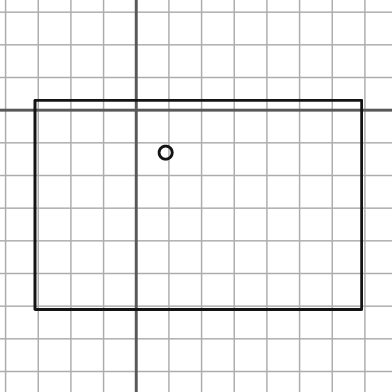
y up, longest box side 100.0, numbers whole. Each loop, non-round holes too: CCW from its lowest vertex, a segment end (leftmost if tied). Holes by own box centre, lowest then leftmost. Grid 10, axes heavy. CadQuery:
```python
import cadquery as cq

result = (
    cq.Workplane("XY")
    .moveTo(-31.0, -61.0)
    .lineTo(69.0, -61.0)
    .lineTo(69.0, 3.0)
    .lineTo(-31.0, 3.0)
    .close()
    .moveTo(9.0, -13.0)
    .circle(2.0)
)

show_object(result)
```